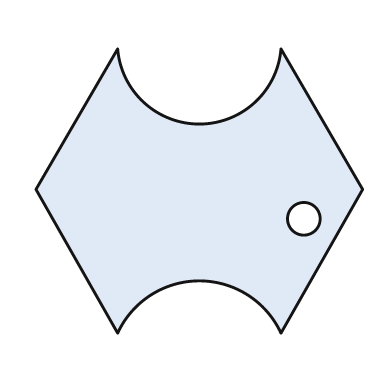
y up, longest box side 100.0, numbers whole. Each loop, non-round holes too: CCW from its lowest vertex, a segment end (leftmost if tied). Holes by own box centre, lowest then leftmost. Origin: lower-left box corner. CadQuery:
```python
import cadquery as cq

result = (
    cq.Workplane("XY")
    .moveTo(25.0, 0.0)
    .threePointArc((50.0, 16.0), (75.0, 0.0))
    .lineTo(100.0, 44.0)
    .lineTo(75.0, 87.0)
    .threePointArc((50.0, 64.0), (25.0, 87.0))
    .lineTo(0.0, 44.0)
    .close()
    .moveTo(82.0, 35.0)
    .circle(5.0)
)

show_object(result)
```